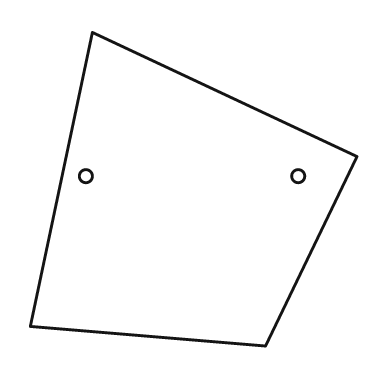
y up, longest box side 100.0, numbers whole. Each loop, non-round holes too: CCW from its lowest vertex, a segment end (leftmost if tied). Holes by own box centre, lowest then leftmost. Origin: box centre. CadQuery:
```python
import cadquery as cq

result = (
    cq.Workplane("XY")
    .moveTo(22.0, -48.0)
    .lineTo(50.0, 10.0)
    .lineTo(-31.0, 48.0)
    .lineTo(-50.0, -42.0)
    .close()
    .moveTo(-33.0, 4.0)
    .circle(2.0)
    .moveTo(32.0, 4.0)
    .circle(2.0)
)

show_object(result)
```